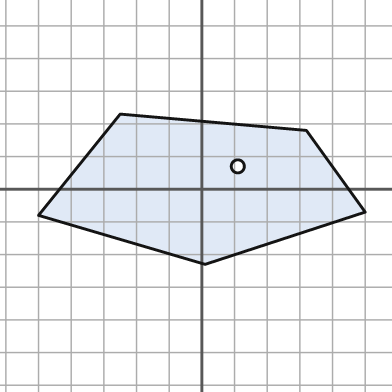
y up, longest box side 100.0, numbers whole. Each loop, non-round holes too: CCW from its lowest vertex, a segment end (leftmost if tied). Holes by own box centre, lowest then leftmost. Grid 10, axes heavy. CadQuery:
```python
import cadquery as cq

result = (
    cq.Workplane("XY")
    .moveTo(1.0, -23.0)
    .lineTo(50.0, -7.0)
    .lineTo(32.0, 18.0)
    .lineTo(-25.0, 23.0)
    .lineTo(-50.0, -8.0)
    .close()
    .moveTo(11.0, 7.0)
    .circle(2.0)
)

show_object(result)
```